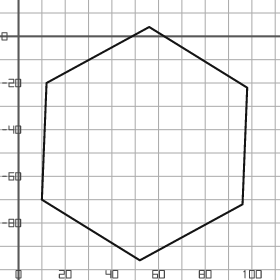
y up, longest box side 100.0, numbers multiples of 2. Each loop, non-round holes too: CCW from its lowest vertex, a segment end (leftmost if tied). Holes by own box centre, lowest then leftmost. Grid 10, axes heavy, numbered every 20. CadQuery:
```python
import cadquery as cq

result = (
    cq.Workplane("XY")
    .moveTo(52.0, -96.0)
    .lineTo(96.0, -72.0)
    .lineTo(98.0, -22.0)
    .lineTo(56.0, 4.0)
    .lineTo(12.0, -20.0)
    .lineTo(10.0, -70.0)
    .close()
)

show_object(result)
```